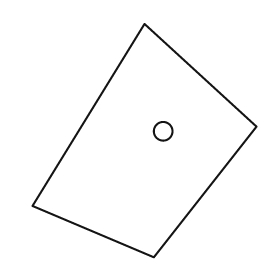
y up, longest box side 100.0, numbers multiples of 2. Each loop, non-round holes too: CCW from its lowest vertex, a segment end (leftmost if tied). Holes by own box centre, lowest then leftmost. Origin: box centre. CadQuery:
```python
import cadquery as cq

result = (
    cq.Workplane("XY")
    .moveTo(4.0, -50.0)
    .lineTo(48.0, 6.0)
    .lineTo(0.0, 50.0)
    .lineTo(-48.0, -28.0)
    .close()
    .moveTo(8.0, 4.0)
    .circle(4.0)
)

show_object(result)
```